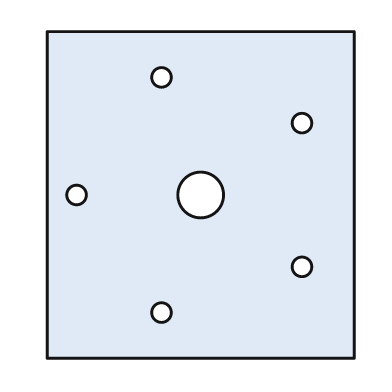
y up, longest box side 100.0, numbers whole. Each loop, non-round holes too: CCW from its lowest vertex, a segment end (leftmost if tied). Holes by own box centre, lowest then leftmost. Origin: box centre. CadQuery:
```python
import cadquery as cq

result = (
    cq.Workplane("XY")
    .moveTo(-47.0, -50.0)
    .lineTo(47.0, -50.0)
    .lineTo(47.0, 50.0)
    .lineTo(-47.0, 50.0)
    .close()
    .moveTo(-12.0, -36.0)
    .circle(3.0)
    .moveTo(31.0, -22.0)
    .circle(3.0)
    .moveTo(-38.0, 0.0)
    .circle(3.0)
    .moveTo(0.0, 0.0)
    .circle(7.0)
    .moveTo(31.0, 22.0)
    .circle(3.0)
    .moveTo(-12.0, 36.0)
    .circle(3.0)
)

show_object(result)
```